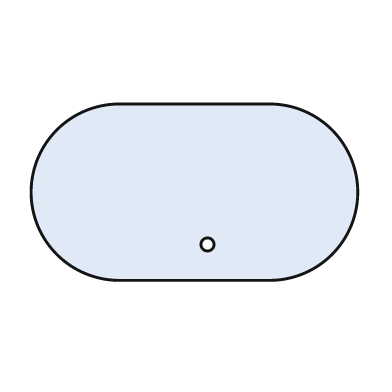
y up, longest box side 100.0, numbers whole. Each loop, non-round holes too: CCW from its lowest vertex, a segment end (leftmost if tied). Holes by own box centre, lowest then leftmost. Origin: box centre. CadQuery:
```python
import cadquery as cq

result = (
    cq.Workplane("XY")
    .moveTo(-23.0, -27.0)
    .lineTo(23.0, -27.0)
    .threePointArc((50.0, 0.0), (23.0, 27.0))
    .lineTo(-23.0, 27.0)
    .threePointArc((-50.0, 0.0), (-23.0, -27.0))
    .close()
    .moveTo(4.0, -16.0)
    .circle(2.0)
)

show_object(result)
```